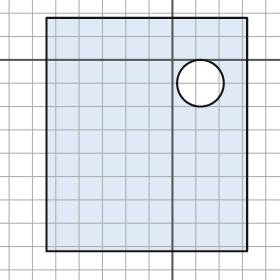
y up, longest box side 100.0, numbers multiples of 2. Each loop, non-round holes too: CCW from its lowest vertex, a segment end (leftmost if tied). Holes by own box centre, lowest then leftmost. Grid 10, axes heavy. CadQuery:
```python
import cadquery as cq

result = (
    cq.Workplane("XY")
    .moveTo(-54.0, -82.0)
    .lineTo(32.0, -82.0)
    .lineTo(32.0, 18.0)
    .lineTo(-54.0, 18.0)
    .close()
    .moveTo(12.0, -10.0)
    .circle(10.0)
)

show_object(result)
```